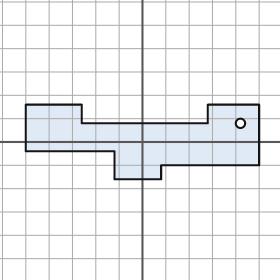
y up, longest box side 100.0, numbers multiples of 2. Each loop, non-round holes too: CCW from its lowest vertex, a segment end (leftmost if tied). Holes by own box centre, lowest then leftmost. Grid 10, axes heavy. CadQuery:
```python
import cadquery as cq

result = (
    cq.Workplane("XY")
    .moveTo(-12.0, -16.0)
    .lineTo(8.0, -16.0)
    .lineTo(8.0, -10.0)
    .lineTo(50.0, -10.0)
    .lineTo(50.0, 16.0)
    .lineTo(28.0, 16.0)
    .lineTo(28.0, 8.0)
    .lineTo(-26.0, 8.0)
    .lineTo(-26.0, 16.0)
    .lineTo(-50.0, 16.0)
    .lineTo(-50.0, -4.0)
    .lineTo(-12.0, -4.0)
    .close()
    .moveTo(42.0, 8.0)
    .circle(2.0)
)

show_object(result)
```